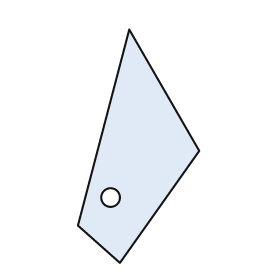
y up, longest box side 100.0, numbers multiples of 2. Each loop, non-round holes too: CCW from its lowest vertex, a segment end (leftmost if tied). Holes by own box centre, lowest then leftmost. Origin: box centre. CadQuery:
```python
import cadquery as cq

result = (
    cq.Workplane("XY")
    .moveTo(-8.0, -50.0)
    .lineTo(26.0, -2.0)
    .lineTo(-4.0, 50.0)
    .lineTo(-26.0, -34.0)
    .close()
    .moveTo(-12.0, -22.0)
    .circle(4.0)
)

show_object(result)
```